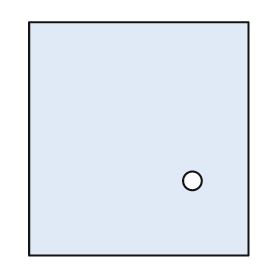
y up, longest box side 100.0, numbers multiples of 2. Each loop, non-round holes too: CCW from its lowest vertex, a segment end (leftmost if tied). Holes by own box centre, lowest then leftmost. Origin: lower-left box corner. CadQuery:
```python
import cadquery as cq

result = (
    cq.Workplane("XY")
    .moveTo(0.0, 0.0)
    .lineTo(94.0, 0.0)
    .lineTo(94.0, 100.0)
    .lineTo(0.0, 100.0)
    .close()
    .moveTo(70.0, 32.0)
    .circle(4.0)
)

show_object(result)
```